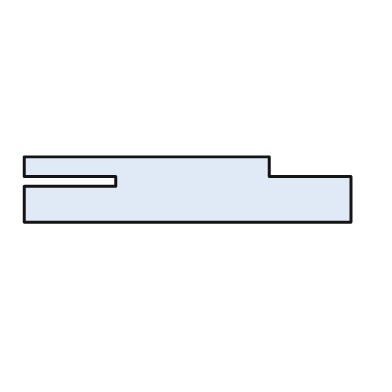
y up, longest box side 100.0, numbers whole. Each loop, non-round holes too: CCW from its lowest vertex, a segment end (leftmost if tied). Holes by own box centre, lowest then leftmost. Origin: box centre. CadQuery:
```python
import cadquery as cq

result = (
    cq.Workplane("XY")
    .moveTo(-50.0, -10.0)
    .lineTo(50.0, -10.0)
    .lineTo(50.0, 4.0)
    .lineTo(25.0, 4.0)
    .lineTo(25.0, 10.0)
    .lineTo(-50.0, 10.0)
    .lineTo(-50.0, 4.0)
    .lineTo(-22.0, 4.0)
    .lineTo(-22.0, 1.0)
    .lineTo(-50.0, 1.0)
    .close()
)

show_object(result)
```